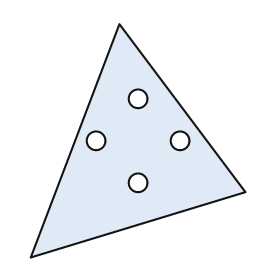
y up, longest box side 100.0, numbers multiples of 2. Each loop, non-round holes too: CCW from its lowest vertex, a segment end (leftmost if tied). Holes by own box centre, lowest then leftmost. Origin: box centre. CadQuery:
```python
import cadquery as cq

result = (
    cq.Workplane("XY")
    .moveTo(-46.0, -50.0)
    .lineTo(46.0, -22.0)
    .lineTo(-8.0, 50.0)
    .close()
    .moveTo(0.0, -18.0)
    .circle(4.0)
    .moveTo(-18.0, 0.0)
    .circle(4.0)
    .moveTo(18.0, 0.0)
    .circle(4.0)
    .moveTo(0.0, 18.0)
    .circle(4.0)
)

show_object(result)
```